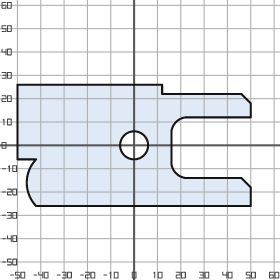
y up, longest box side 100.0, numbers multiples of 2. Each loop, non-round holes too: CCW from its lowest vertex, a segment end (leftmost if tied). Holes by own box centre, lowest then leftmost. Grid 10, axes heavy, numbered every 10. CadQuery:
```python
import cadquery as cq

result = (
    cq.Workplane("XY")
    .moveTo(-42.0, -26.0)
    .lineTo(50.0, -26.0)
    .lineTo(50.0, -18.0)
    .lineTo(46.0, -14.0)
    .lineTo(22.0, -14.0)
    .threePointArc((18.0, -12.0), (16.0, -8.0))
    .lineTo(16.0, 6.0)
    .threePointArc((18.0, 10.0), (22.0, 12.0))
    .lineTo(50.0, 12.0)
    .lineTo(50.0, 18.0)
    .lineTo(46.0, 22.0)
    .lineTo(12.0, 22.0)
    .lineTo(12.0, 26.0)
    .lineTo(-50.0, 26.0)
    .lineTo(-50.0, -6.0)
    .lineTo(-42.0, -6.0)
    .threePointArc((-46.0, -16.0), (-42.0, -26.0))
    .close()
    .moveTo(0.0, 0.0)
    .circle(6.0)
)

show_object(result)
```